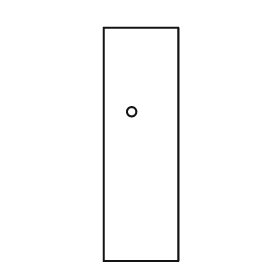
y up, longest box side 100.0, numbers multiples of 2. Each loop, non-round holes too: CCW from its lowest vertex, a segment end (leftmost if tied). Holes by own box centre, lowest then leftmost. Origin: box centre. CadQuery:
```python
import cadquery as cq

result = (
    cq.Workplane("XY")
    .moveTo(-16.0, -50.0)
    .lineTo(16.0, -50.0)
    .lineTo(16.0, 50.0)
    .lineTo(-16.0, 50.0)
    .close()
    .moveTo(-4.0, 14.0)
    .circle(2.0)
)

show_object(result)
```